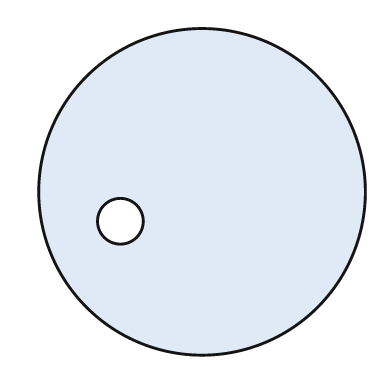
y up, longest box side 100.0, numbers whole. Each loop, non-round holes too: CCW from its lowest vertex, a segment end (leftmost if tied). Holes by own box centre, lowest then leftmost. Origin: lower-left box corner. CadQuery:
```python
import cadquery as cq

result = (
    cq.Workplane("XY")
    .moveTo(50.0, 50.0)
    .circle(50.0)
    .moveTo(25.0, 41.0)
    .circle(7.0)
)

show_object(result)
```